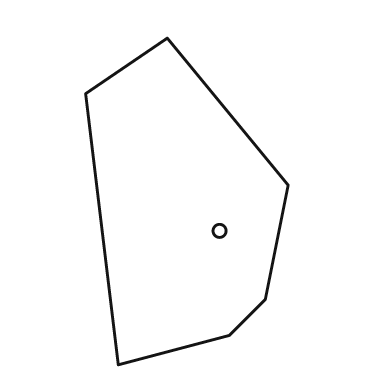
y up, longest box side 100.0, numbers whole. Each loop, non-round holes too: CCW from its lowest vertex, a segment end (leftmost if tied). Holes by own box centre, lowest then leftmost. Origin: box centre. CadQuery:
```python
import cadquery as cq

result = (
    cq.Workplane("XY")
    .moveTo(-21.0, -50.0)
    .lineTo(13.0, -41.0)
    .lineTo(24.0, -30.0)
    .lineTo(31.0, 5.0)
    .lineTo(-6.0, 50.0)
    .lineTo(-31.0, 33.0)
    .close()
    .moveTo(10.0, -9.0)
    .circle(2.0)
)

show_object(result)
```